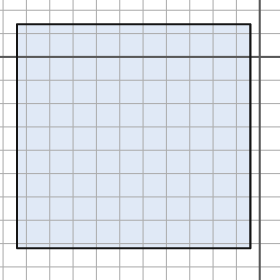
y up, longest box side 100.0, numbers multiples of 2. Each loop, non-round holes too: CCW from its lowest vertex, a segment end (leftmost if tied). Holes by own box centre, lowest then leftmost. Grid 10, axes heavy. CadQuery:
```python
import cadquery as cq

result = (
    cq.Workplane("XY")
    .moveTo(-104.0, -82.0)
    .lineTo(-4.0, -82.0)
    .lineTo(-4.0, 14.0)
    .lineTo(-104.0, 14.0)
    .close()
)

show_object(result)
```